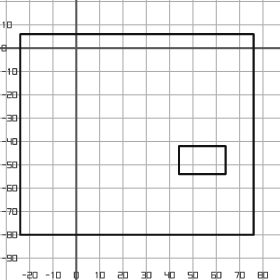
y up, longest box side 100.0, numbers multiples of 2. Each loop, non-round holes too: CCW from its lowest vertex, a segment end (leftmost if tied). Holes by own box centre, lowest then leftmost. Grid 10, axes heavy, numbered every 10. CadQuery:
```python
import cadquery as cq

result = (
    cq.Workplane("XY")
    .moveTo(-24.0, -80.0)
    .lineTo(76.0, -80.0)
    .lineTo(76.0, 6.0)
    .lineTo(-24.0, 6.0)
    .close()
    .moveTo(44.0, -54.0)
    .lineTo(64.0, -54.0)
    .lineTo(64.0, -42.0)
    .lineTo(44.0, -42.0)
    .close()
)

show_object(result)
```